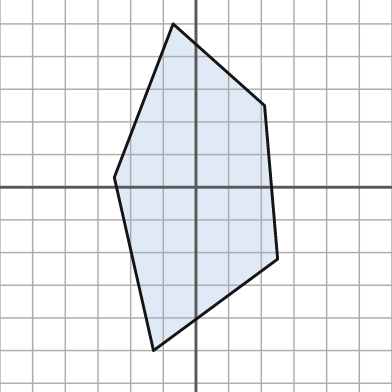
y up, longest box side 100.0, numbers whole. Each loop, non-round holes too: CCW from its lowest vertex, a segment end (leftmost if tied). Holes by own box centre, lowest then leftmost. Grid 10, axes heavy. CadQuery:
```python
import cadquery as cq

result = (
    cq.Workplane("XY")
    .moveTo(-13.0, -50.0)
    .lineTo(25.0, -22.0)
    .lineTo(21.0, 25.0)
    .lineTo(-7.0, 50.0)
    .lineTo(-25.0, 3.0)
    .close()
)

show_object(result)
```